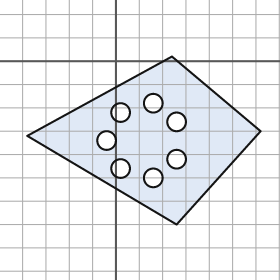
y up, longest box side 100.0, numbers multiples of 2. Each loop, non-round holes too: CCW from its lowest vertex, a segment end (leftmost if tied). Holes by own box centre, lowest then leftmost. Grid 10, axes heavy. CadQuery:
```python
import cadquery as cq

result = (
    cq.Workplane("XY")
    .moveTo(26.0, -70.0)
    .lineTo(62.0, -30.0)
    .lineTo(24.0, 2.0)
    .lineTo(-38.0, -32.0)
    .close()
    .moveTo(16.0, -50.0)
    .circle(4.0)
    .moveTo(2.0, -46.0)
    .circle(4.0)
    .moveTo(26.0, -42.0)
    .circle(4.0)
    .moveTo(-4.0, -34.0)
    .circle(4.0)
    .moveTo(26.0, -26.0)
    .circle(4.0)
    .moveTo(2.0, -22.0)
    .circle(4.0)
    .moveTo(16.0, -18.0)
    .circle(4.0)
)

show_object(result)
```